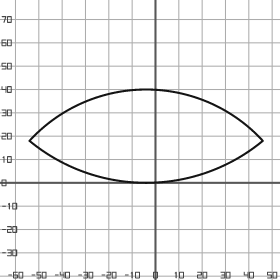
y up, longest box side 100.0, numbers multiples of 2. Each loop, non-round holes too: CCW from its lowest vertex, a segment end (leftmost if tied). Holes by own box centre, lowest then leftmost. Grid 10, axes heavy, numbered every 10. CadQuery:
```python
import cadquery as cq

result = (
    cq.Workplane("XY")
    .moveTo(-54.0, 18.0)
    .threePointArc((-4.0, 0.0), (46.0, 18.0))
    .threePointArc((-4.0, 40.0), (-54.0, 18.0))
    .close()
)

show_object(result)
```